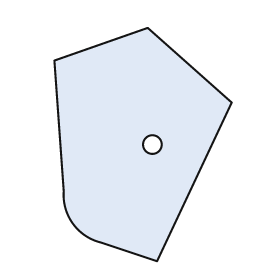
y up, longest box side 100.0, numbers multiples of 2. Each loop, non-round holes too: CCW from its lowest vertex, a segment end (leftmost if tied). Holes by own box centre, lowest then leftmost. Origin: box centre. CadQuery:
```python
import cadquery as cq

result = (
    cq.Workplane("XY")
    .moveTo(6.0, -50.0)
    .lineTo(38.0, 18.0)
    .lineTo(2.0, 50.0)
    .lineTo(-38.0, 36.0)
    .lineTo(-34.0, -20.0)
    .threePointArc((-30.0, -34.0), (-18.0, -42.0))
    .close()
    .moveTo(4.0, 0.0)
    .circle(4.0)
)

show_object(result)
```